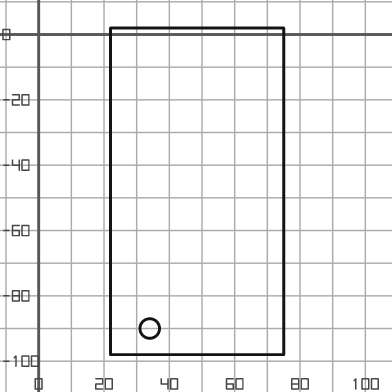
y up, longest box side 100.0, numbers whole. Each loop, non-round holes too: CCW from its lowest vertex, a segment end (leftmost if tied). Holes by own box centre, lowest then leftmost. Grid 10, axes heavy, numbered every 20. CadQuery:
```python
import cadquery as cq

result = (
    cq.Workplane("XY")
    .moveTo(22.0, -98.0)
    .lineTo(75.0, -98.0)
    .lineTo(75.0, 2.0)
    .lineTo(22.0, 2.0)
    .close()
    .moveTo(34.0, -90.0)
    .circle(3.0)
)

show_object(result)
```